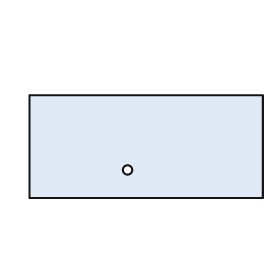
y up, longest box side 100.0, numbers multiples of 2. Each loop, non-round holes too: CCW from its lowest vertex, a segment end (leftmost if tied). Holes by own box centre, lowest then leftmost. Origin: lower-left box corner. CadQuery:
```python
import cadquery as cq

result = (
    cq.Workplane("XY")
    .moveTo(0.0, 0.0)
    .lineTo(100.0, 0.0)
    .lineTo(100.0, 44.0)
    .lineTo(0.0, 44.0)
    .close()
    .moveTo(42.0, 12.0)
    .circle(2.0)
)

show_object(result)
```